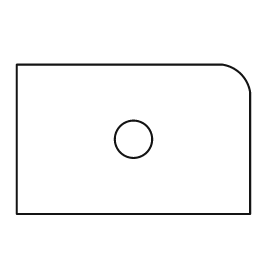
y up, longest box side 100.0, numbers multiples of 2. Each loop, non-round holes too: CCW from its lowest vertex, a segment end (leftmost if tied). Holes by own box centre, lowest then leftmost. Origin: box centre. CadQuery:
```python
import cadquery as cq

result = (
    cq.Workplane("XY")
    .moveTo(-50.0, -32.0)
    .lineTo(50.0, -32.0)
    .lineTo(50.0, 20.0)
    .threePointArc((46.0, 28.0), (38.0, 32.0))
    .lineTo(-50.0, 32.0)
    .close()
    .moveTo(0.0, 0.0)
    .circle(8.0)
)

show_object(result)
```